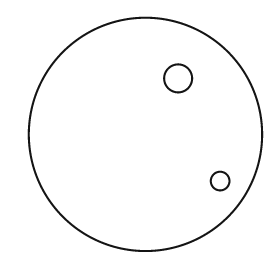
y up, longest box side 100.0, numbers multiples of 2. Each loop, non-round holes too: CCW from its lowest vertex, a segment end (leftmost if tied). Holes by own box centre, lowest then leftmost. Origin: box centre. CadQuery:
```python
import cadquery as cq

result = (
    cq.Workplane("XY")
    .moveTo(0.0, 0.0)
    .circle(50.0)
    .moveTo(32.0, -20.0)
    .circle(4.0)
    .moveTo(14.0, 24.0)
    .circle(6.0)
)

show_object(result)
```